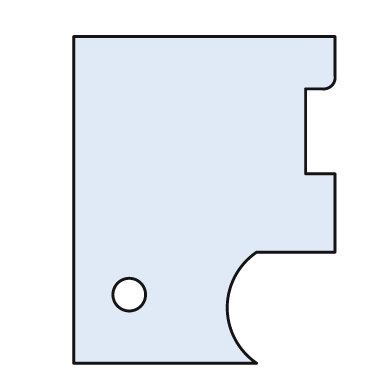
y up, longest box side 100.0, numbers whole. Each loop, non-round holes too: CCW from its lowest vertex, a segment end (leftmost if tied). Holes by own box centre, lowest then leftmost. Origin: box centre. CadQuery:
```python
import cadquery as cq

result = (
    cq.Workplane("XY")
    .moveTo(-40.0, -50.0)
    .lineTo(16.0, -50.0)
    .threePointArc((7.0, -33.0), (16.0, -16.0))
    .lineTo(40.0, -16.0)
    .lineTo(40.0, 8.0)
    .lineTo(31.0, 8.0)
    .lineTo(31.0, 34.0)
    .lineTo(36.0, 34.0)
    .threePointArc((39.0, 35.0), (40.0, 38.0))
    .lineTo(40.0, 50.0)
    .lineTo(-40.0, 50.0)
    .close()
    .moveTo(-23.0, -29.0)
    .circle(5.0)
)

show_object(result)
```